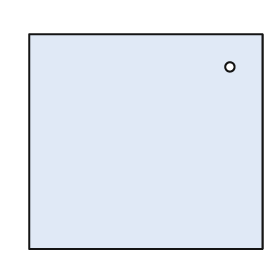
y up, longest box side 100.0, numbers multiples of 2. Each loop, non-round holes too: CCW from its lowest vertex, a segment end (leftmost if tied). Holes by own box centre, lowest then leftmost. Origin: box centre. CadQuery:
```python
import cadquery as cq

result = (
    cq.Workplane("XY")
    .moveTo(-50.0, -46.0)
    .lineTo(50.0, -46.0)
    .lineTo(50.0, 46.0)
    .lineTo(-50.0, 46.0)
    .close()
    .moveTo(36.0, 32.0)
    .circle(2.0)
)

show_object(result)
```